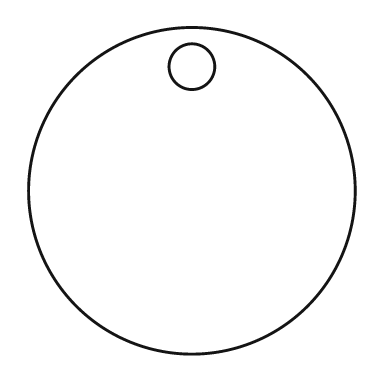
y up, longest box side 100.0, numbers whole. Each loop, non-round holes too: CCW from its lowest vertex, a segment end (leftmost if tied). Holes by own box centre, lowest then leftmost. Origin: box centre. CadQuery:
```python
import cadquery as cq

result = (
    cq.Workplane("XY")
    .moveTo(0.0, 0.0)
    .circle(50.0)
    .moveTo(0.0, 38.0)
    .circle(7.0)
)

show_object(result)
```